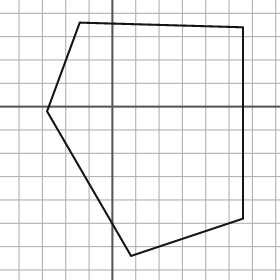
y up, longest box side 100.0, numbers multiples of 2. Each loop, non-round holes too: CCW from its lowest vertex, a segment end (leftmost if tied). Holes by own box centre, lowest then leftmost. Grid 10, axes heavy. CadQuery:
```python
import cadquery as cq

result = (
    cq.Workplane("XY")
    .moveTo(8.0, -64.0)
    .lineTo(56.0, -48.0)
    .lineTo(56.0, 34.0)
    .lineTo(-14.0, 36.0)
    .lineTo(-28.0, -2.0)
    .close()
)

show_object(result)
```